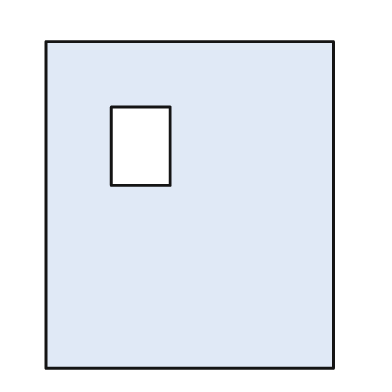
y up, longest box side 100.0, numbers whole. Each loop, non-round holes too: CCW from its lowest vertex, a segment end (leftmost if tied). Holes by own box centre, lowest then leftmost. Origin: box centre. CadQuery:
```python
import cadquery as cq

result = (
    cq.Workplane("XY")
    .moveTo(-44.0, -50.0)
    .lineTo(44.0, -50.0)
    .lineTo(44.0, 50.0)
    .lineTo(-44.0, 50.0)
    .close()
    .moveTo(-24.0, 6.0)
    .lineTo(-6.0, 6.0)
    .lineTo(-6.0, 30.0)
    .lineTo(-24.0, 30.0)
    .close()
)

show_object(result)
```